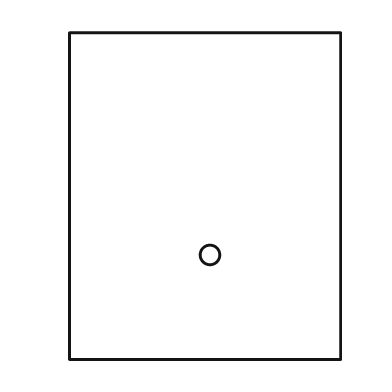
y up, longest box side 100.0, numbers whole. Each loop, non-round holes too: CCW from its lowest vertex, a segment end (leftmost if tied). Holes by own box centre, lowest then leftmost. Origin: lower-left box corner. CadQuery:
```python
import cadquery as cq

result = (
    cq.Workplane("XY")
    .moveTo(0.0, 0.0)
    .lineTo(83.0, 0.0)
    .lineTo(83.0, 100.0)
    .lineTo(0.0, 100.0)
    .close()
    .moveTo(43.0, 32.0)
    .circle(3.0)
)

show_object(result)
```